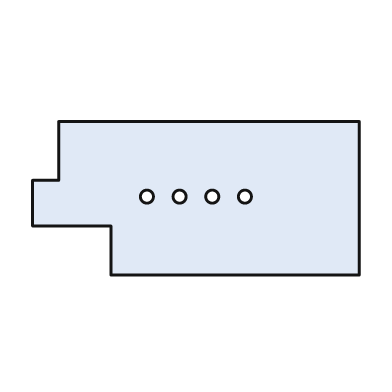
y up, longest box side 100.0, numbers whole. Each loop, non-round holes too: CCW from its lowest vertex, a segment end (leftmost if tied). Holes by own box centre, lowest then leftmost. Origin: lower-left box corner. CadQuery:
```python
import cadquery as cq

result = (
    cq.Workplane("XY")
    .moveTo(24.0, 0.0)
    .lineTo(100.0, 0.0)
    .lineTo(100.0, 47.0)
    .lineTo(8.0, 47.0)
    .lineTo(8.0, 29.0)
    .lineTo(0.0, 29.0)
    .lineTo(0.0, 15.0)
    .lineTo(24.0, 15.0)
    .close()
    .moveTo(35.0, 24.0)
    .circle(2.0)
    .moveTo(45.0, 24.0)
    .circle(2.0)
    .moveTo(55.0, 24.0)
    .circle(2.0)
    .moveTo(65.0, 24.0)
    .circle(2.0)
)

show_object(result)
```